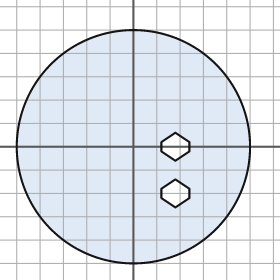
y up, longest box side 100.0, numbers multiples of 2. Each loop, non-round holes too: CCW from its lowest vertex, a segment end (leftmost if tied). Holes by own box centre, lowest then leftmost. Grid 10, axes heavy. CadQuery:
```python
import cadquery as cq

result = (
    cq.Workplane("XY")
    .moveTo(0.0, 0.0)
    .circle(50.0)
    .moveTo(18.0, -26.0)
    .lineTo(24.0, -22.0)
    .lineTo(24.0, -18.0)
    .lineTo(18.0, -14.0)
    .lineTo(12.0, -18.0)
    .lineTo(12.0, -22.0)
    .close()
    .moveTo(18.0, -6.0)
    .lineTo(24.0, -2.0)
    .lineTo(24.0, 2.0)
    .lineTo(18.0, 6.0)
    .lineTo(12.0, 2.0)
    .lineTo(12.0, -2.0)
    .close()
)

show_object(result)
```